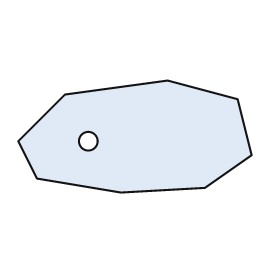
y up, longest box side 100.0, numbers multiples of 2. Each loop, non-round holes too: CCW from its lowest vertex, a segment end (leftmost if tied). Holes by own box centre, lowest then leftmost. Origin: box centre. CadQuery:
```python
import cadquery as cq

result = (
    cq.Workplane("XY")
    .moveTo(-6.0, -24.0)
    .lineTo(30.0, -22.0)
    .lineTo(50.0, -8.0)
    .lineTo(44.0, 16.0)
    .lineTo(14.0, 24.0)
    .lineTo(-30.0, 18.0)
    .lineTo(-50.0, -2.0)
    .lineTo(-42.0, -18.0)
    .close()
    .moveTo(-20.0, -2.0)
    .circle(4.0)
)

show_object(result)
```